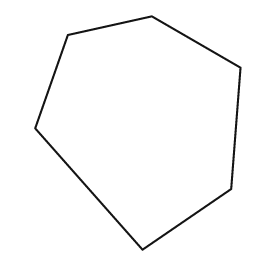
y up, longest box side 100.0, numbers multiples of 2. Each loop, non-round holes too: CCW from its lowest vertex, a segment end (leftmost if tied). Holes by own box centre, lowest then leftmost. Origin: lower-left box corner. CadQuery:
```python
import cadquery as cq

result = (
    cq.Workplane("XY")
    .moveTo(46.0, 0.0)
    .lineTo(84.0, 26.0)
    .lineTo(88.0, 78.0)
    .lineTo(50.0, 100.0)
    .lineTo(14.0, 92.0)
    .lineTo(0.0, 52.0)
    .close()
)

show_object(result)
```